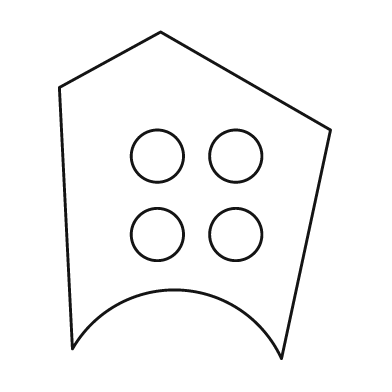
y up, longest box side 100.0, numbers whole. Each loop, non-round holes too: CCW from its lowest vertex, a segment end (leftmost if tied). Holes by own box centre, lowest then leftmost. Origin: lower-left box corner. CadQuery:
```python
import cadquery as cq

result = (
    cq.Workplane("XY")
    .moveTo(68.0, 0.0)
    .lineTo(83.0, 70.0)
    .lineTo(31.0, 100.0)
    .lineTo(0.0, 83.0)
    .lineTo(4.0, 3.0)
    .threePointArc((37.0, 21.0), (68.0, 0.0))
    .close()
    .moveTo(30.0, 38.0)
    .circle(8.0)
    .moveTo(54.0, 38.0)
    .circle(8.0)
    .moveTo(30.0, 62.0)
    .circle(8.0)
    .moveTo(54.0, 62.0)
    .circle(8.0)
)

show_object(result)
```